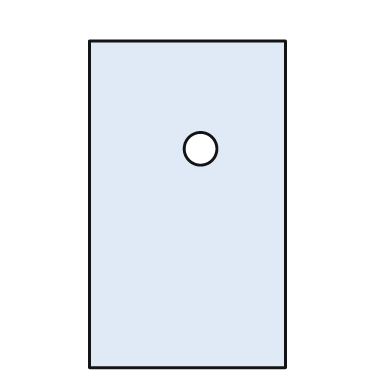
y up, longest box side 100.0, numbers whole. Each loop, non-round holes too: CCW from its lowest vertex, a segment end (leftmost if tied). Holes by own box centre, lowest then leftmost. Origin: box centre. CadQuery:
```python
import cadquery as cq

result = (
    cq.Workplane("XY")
    .moveTo(-30.0, -50.0)
    .lineTo(30.0, -50.0)
    .lineTo(30.0, 50.0)
    .lineTo(-30.0, 50.0)
    .close()
    .moveTo(4.0, 17.0)
    .circle(5.0)
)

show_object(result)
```